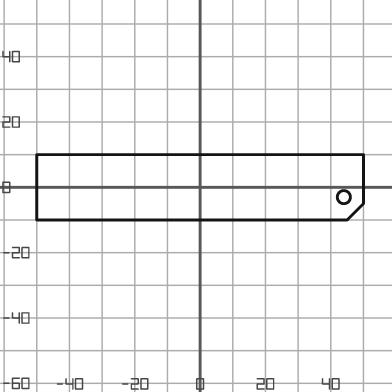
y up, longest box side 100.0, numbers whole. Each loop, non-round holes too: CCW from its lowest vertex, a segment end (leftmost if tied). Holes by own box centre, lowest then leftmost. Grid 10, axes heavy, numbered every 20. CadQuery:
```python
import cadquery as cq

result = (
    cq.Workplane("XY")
    .moveTo(-50.0, -10.0)
    .lineTo(45.0, -10.0)
    .lineTo(50.0, -5.0)
    .lineTo(50.0, 10.0)
    .lineTo(-50.0, 10.0)
    .close()
    .moveTo(44.0, -3.0)
    .circle(2.0)
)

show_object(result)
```